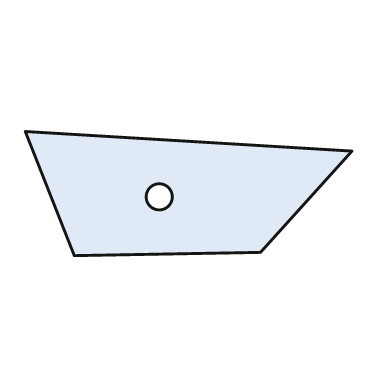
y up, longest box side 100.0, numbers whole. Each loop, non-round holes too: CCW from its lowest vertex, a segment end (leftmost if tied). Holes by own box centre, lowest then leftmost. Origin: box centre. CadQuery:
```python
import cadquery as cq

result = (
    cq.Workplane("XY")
    .moveTo(-35.0, -19.0)
    .lineTo(22.0, -18.0)
    .lineTo(50.0, 13.0)
    .lineTo(-50.0, 19.0)
    .close()
    .moveTo(-9.0, -1.0)
    .circle(4.0)
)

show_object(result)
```